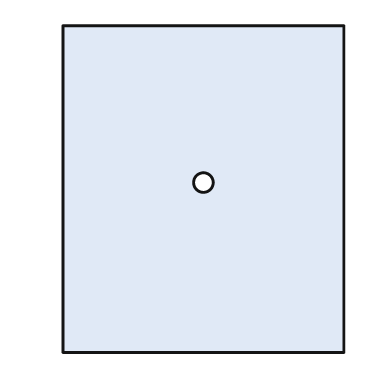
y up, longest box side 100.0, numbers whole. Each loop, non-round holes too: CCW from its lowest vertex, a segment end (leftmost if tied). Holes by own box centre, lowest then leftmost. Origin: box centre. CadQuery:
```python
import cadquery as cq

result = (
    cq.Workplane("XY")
    .moveTo(-43.0, -50.0)
    .lineTo(43.0, -50.0)
    .lineTo(43.0, 50.0)
    .lineTo(-43.0, 50.0)
    .close()
    .moveTo(0.0, 2.0)
    .circle(3.0)
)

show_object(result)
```